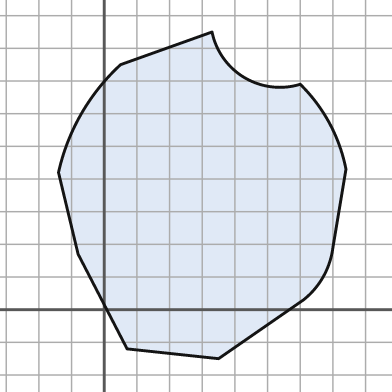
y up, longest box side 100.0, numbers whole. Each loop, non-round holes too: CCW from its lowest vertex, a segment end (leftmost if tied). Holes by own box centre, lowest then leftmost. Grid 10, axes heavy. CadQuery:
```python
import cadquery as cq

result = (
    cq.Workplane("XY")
    .moveTo(35.0, -15.0)
    .lineTo(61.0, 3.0)
    .threePointArc((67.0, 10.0), (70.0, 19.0))
    .lineTo(74.0, 43.0)
    .threePointArc((69.0, 57.0), (60.0, 69.0))
    .threePointArc((43.0, 71.0), (33.0, 85.0))
    .lineTo(5.0, 75.0)
    .threePointArc((-7.0, 60.0), (-14.0, 42.0))
    .lineTo(-8.0, 17.0)
    .lineTo(7.0, -12.0)
    .close()
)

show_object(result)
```